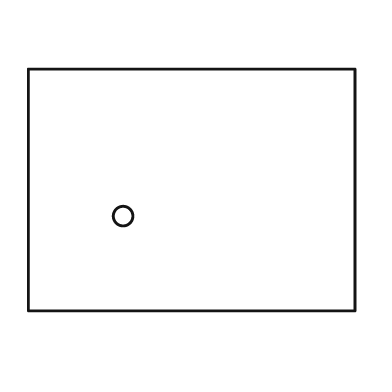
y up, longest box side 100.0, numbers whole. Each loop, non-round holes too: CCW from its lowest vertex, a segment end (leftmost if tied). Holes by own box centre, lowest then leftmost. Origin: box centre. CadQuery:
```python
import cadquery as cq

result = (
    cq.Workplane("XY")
    .moveTo(-50.0, -37.0)
    .lineTo(50.0, -37.0)
    .lineTo(50.0, 37.0)
    .lineTo(-50.0, 37.0)
    .close()
    .moveTo(-21.0, -8.0)
    .circle(3.0)
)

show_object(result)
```